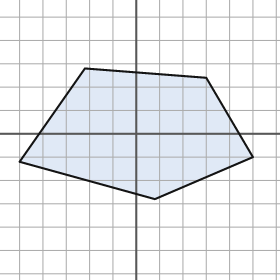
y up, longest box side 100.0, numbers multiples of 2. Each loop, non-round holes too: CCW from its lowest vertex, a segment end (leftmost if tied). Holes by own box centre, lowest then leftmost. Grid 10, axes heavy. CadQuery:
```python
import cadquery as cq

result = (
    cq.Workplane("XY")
    .moveTo(8.0, -28.0)
    .lineTo(50.0, -10.0)
    .lineTo(30.0, 24.0)
    .lineTo(-22.0, 28.0)
    .lineTo(-50.0, -12.0)
    .close()
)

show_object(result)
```